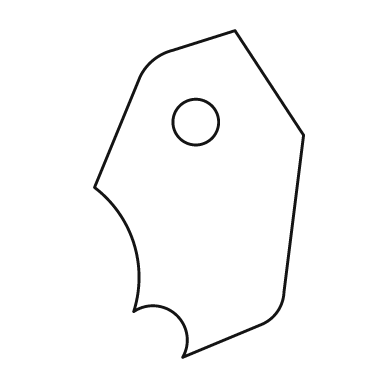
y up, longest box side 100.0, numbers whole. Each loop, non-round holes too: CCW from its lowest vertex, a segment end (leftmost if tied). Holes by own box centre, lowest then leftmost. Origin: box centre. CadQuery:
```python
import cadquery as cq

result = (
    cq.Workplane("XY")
    .moveTo(-5.0, -50.0)
    .lineTo(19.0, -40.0)
    .threePointArc((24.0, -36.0), (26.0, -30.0))
    .lineTo(32.0, 18.0)
    .lineTo(11.0, 50.0)
    .lineTo(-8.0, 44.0)
    .threePointArc((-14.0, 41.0), (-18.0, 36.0))
    .lineTo(-32.0, 2.0)
    .threePointArc((-20.0, -15.0), (-20.0, -36.0))
    .threePointArc((-7.0, -37.0), (-5.0, -50.0))
    .close()
    .moveTo(-1.0, 22.0)
    .circle(7.0)
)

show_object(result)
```